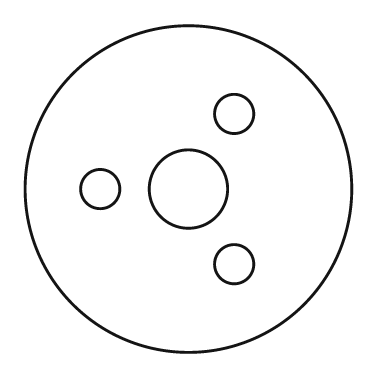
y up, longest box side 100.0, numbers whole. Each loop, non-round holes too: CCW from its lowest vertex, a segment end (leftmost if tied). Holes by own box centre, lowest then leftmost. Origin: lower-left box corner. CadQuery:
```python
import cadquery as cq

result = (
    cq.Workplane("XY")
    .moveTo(50.0, 50.0)
    .circle(50.0)
    .moveTo(64.0, 27.0)
    .circle(6.0)
    .moveTo(23.0, 50.0)
    .circle(6.0)
    .moveTo(50.0, 50.0)
    .circle(12.0)
    .moveTo(64.0, 73.0)
    .circle(6.0)
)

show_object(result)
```